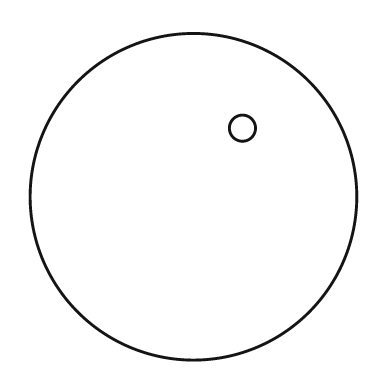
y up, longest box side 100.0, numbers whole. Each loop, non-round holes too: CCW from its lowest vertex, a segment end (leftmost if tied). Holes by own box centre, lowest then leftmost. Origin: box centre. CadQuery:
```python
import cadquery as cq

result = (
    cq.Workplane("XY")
    .moveTo(0.0, 0.0)
    .circle(50.0)
    .moveTo(15.0, 21.0)
    .circle(4.0)
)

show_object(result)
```